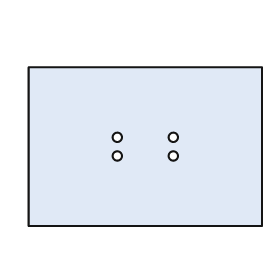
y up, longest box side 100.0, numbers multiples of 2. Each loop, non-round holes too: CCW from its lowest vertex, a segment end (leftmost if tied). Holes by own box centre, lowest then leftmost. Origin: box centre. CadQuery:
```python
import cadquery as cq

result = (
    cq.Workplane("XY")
    .moveTo(-50.0, -34.0)
    .lineTo(50.0, -34.0)
    .lineTo(50.0, 34.0)
    .lineTo(-50.0, 34.0)
    .close()
    .moveTo(-12.0, -4.0)
    .circle(2.0)
    .moveTo(12.0, -4.0)
    .circle(2.0)
    .moveTo(-12.0, 4.0)
    .circle(2.0)
    .moveTo(12.0, 4.0)
    .circle(2.0)
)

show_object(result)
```